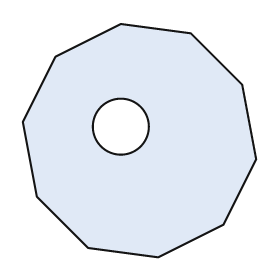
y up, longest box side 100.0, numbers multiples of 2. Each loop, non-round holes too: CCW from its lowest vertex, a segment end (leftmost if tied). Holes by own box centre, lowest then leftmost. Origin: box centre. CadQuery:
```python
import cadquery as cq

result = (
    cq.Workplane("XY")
    .moveTo(8.0, -50.0)
    .lineTo(36.0, -36.0)
    .lineTo(50.0, -8.0)
    .lineTo(44.0, 24.0)
    .lineTo(22.0, 46.0)
    .lineTo(-8.0, 50.0)
    .lineTo(-36.0, 36.0)
    .lineTo(-50.0, 8.0)
    .lineTo(-44.0, -24.0)
    .lineTo(-22.0, -46.0)
    .close()
    .moveTo(-8.0, 6.0)
    .circle(12.0)
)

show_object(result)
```